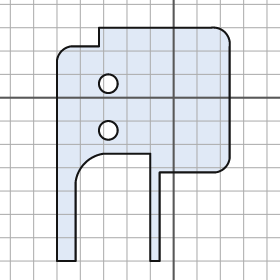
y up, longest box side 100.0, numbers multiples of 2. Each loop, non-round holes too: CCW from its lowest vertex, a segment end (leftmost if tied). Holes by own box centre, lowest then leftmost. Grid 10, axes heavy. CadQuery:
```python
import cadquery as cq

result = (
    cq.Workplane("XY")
    .moveTo(-50.0, -70.0)
    .lineTo(-42.0, -70.0)
    .lineTo(-42.0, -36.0)
    .threePointArc((-38.0, -28.0), (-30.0, -24.0))
    .lineTo(-10.0, -24.0)
    .lineTo(-10.0, -70.0)
    .lineTo(-6.0, -70.0)
    .lineTo(-6.0, -32.0)
    .lineTo(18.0, -32.0)
    .threePointArc((22.0, -30.0), (24.0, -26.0))
    .lineTo(24.0, 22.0)
    .threePointArc((22.0, 28.0), (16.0, 30.0))
    .lineTo(-32.0, 30.0)
    .lineTo(-32.0, 22.0)
    .lineTo(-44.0, 22.0)
    .threePointArc((-48.0, 20.0), (-50.0, 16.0))
    .close()
    .moveTo(-28.0, -14.0)
    .circle(4.0)
    .moveTo(-28.0, 6.0)
    .circle(4.0)
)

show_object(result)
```